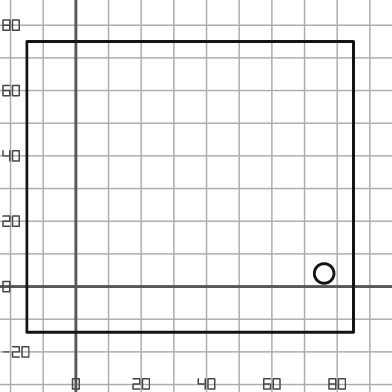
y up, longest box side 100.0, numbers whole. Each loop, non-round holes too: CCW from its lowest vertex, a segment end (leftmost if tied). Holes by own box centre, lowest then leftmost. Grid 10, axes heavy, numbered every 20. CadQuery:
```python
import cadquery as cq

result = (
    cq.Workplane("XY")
    .moveTo(-15.0, -14.0)
    .lineTo(85.0, -14.0)
    .lineTo(85.0, 75.0)
    .lineTo(-15.0, 75.0)
    .close()
    .moveTo(76.0, 4.0)
    .circle(3.0)
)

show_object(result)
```